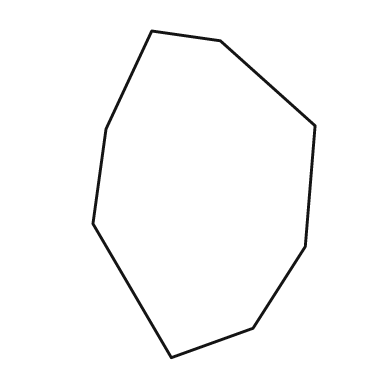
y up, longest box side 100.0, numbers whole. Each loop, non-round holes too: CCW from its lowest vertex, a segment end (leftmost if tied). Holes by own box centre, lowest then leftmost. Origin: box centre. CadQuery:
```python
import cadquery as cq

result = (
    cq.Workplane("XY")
    .moveTo(-10.0, -50.0)
    .lineTo(15.0, -41.0)
    .lineTo(31.0, -16.0)
    .lineTo(34.0, 21.0)
    .lineTo(5.0, 47.0)
    .lineTo(-16.0, 50.0)
    .lineTo(-30.0, 20.0)
    .lineTo(-34.0, -9.0)
    .close()
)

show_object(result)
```